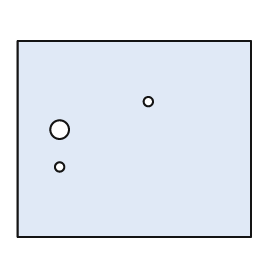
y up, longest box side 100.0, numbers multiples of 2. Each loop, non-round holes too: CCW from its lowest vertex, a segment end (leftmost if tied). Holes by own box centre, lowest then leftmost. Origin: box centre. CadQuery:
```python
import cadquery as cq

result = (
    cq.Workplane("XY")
    .moveTo(-50.0, -42.0)
    .lineTo(50.0, -42.0)
    .lineTo(50.0, 42.0)
    .lineTo(-50.0, 42.0)
    .close()
    .moveTo(-32.0, -12.0)
    .circle(2.0)
    .moveTo(-32.0, 4.0)
    .circle(4.0)
    .moveTo(6.0, 16.0)
    .circle(2.0)
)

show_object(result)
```